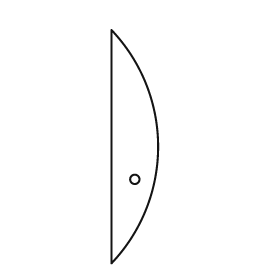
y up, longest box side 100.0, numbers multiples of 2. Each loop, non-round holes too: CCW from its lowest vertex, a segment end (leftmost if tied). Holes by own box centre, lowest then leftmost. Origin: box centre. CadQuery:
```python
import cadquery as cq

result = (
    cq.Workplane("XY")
    .moveTo(-10.0, -50.0)
    .threePointArc((10.0, 0.0), (-10.0, 50.0))
    .close()
    .moveTo(0.0, -14.0)
    .circle(2.0)
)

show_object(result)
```